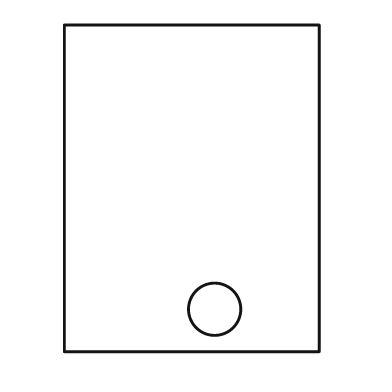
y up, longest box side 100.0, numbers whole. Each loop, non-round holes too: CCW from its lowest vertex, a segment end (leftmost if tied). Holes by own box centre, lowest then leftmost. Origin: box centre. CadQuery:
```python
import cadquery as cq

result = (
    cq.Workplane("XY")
    .moveTo(-39.0, -50.0)
    .lineTo(39.0, -50.0)
    .lineTo(39.0, 50.0)
    .lineTo(-39.0, 50.0)
    .close()
    .moveTo(7.0, -37.0)
    .circle(8.0)
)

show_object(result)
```